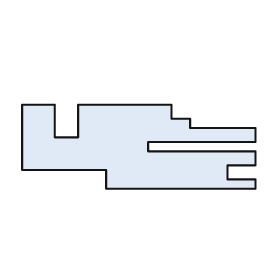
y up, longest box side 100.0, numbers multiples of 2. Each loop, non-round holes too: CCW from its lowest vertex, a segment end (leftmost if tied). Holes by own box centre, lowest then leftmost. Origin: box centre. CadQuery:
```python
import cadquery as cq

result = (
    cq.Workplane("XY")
    .moveTo(-14.0, -18.0)
    .lineTo(50.0, -18.0)
    .lineTo(50.0, -14.0)
    .lineTo(38.0, -14.0)
    .lineTo(38.0, -8.0)
    .lineTo(50.0, -8.0)
    .lineTo(50.0, -2.0)
    .lineTo(4.0, -2.0)
    .lineTo(4.0, 2.0)
    .lineTo(50.0, 2.0)
    .lineTo(50.0, 8.0)
    .lineTo(22.0, 8.0)
    .lineTo(22.0, 12.0)
    .lineTo(14.0, 12.0)
    .lineTo(14.0, 18.0)
    .lineTo(-26.0, 18.0)
    .lineTo(-26.0, 4.0)
    .lineTo(-36.0, 4.0)
    .lineTo(-36.0, 18.0)
    .lineTo(-50.0, 18.0)
    .lineTo(-50.0, -10.0)
    .lineTo(-14.0, -10.0)
    .close()
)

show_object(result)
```